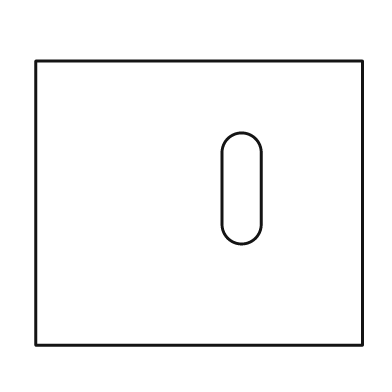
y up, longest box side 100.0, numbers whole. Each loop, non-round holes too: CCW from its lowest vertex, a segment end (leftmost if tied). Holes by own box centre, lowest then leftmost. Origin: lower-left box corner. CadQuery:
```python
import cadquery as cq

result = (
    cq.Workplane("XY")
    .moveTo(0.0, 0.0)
    .lineTo(100.0, 0.0)
    .lineTo(100.0, 87.0)
    .lineTo(0.0, 87.0)
    .close()
    .moveTo(57.0, 37.0)
    .threePointArc((63.0, 31.0), (69.0, 37.0))
    .lineTo(69.0, 59.0)
    .threePointArc((63.0, 65.0), (57.0, 59.0))
    .close()
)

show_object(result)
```